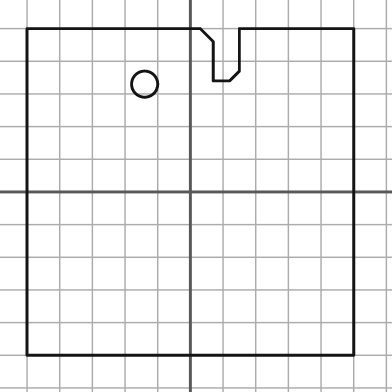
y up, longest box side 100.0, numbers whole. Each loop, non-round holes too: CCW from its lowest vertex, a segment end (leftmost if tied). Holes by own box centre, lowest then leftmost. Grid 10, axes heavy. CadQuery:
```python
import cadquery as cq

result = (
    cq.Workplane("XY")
    .moveTo(-50.0, -50.0)
    .lineTo(50.0, -50.0)
    .lineTo(50.0, 50.0)
    .lineTo(15.0, 50.0)
    .lineTo(15.0, 37.0)
    .lineTo(12.0, 34.0)
    .lineTo(7.0, 34.0)
    .lineTo(7.0, 46.0)
    .lineTo(3.0, 50.0)
    .lineTo(-50.0, 50.0)
    .close()
    .moveTo(-14.0, 33.0)
    .circle(4.0)
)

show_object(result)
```